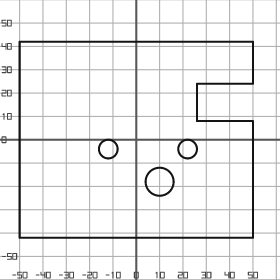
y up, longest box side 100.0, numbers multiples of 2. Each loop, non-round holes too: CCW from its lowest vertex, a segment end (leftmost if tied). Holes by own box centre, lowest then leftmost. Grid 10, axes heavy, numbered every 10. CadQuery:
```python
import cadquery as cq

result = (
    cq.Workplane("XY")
    .moveTo(-50.0, -42.0)
    .lineTo(50.0, -42.0)
    .lineTo(50.0, 8.0)
    .lineTo(26.0, 8.0)
    .lineTo(26.0, 24.0)
    .lineTo(50.0, 24.0)
    .lineTo(50.0, 42.0)
    .lineTo(-50.0, 42.0)
    .close()
    .moveTo(10.0, -18.0)
    .circle(6.0)
    .moveTo(-12.0, -4.0)
    .circle(4.0)
    .moveTo(22.0, -4.0)
    .circle(4.0)
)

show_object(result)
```